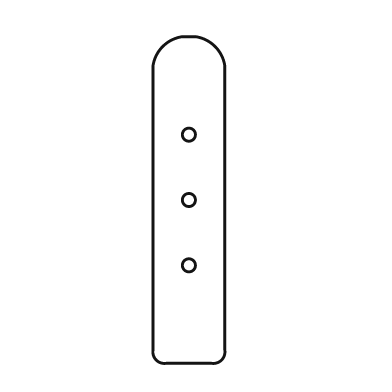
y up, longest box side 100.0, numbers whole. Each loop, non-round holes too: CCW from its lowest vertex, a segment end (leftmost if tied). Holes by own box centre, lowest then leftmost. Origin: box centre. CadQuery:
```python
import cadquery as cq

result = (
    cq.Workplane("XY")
    .moveTo(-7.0, -50.0)
    .lineTo(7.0, -50.0)
    .threePointArc((10.0, -49.0), (11.0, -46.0))
    .lineTo(11.0, 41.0)
    .threePointArc((8.0, 47.0), (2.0, 50.0))
    .lineTo(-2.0, 50.0)
    .threePointArc((-8.0, 47.0), (-11.0, 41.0))
    .lineTo(-11.0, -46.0)
    .threePointArc((-10.0, -49.0), (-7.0, -50.0))
    .close()
    .moveTo(0.0, -20.0)
    .circle(2.0)
    .moveTo(0.0, 0.0)
    .circle(2.0)
    .moveTo(0.0, 20.0)
    .circle(2.0)
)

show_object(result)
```